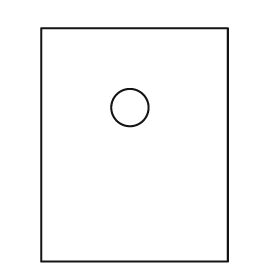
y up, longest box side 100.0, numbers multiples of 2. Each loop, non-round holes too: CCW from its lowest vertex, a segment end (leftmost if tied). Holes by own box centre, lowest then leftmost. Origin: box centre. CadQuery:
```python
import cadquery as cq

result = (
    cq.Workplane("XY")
    .moveTo(-40.0, -50.0)
    .lineTo(40.0, -50.0)
    .lineTo(40.0, 50.0)
    .lineTo(-40.0, 50.0)
    .close()
    .moveTo(-2.0, 16.0)
    .circle(8.0)
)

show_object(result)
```